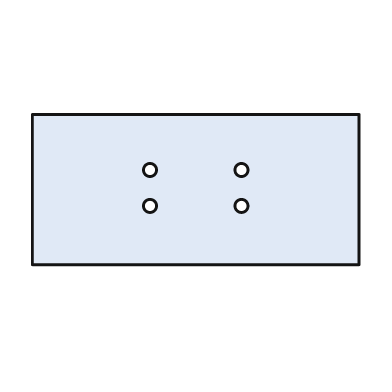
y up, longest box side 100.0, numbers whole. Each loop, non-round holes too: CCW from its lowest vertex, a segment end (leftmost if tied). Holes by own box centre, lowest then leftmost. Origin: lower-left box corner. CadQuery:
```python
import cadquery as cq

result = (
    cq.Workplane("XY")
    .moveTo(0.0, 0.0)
    .lineTo(100.0, 0.0)
    .lineTo(100.0, 46.0)
    .lineTo(0.0, 46.0)
    .close()
    .moveTo(36.0, 18.0)
    .circle(2.0)
    .moveTo(64.0, 18.0)
    .circle(2.0)
    .moveTo(36.0, 29.0)
    .circle(2.0)
    .moveTo(64.0, 29.0)
    .circle(2.0)
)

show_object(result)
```